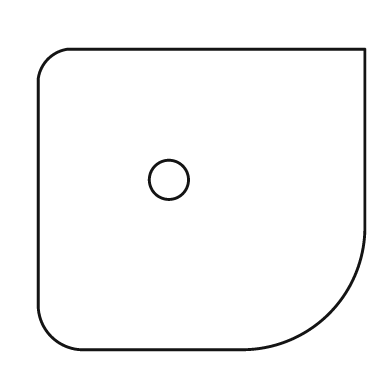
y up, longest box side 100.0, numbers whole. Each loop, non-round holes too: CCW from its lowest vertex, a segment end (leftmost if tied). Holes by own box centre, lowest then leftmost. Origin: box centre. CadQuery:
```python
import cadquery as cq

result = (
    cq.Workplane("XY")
    .moveTo(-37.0, -46.0)
    .lineTo(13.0, -46.0)
    .threePointArc((39.0, -35.0), (50.0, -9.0))
    .lineTo(50.0, 46.0)
    .lineTo(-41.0, 46.0)
    .threePointArc((-47.0, 43.0), (-50.0, 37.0))
    .lineTo(-50.0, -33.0)
    .threePointArc((-46.0, -42.0), (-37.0, -46.0))
    .close()
    .moveTo(-10.0, 6.0)
    .circle(6.0)
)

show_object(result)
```